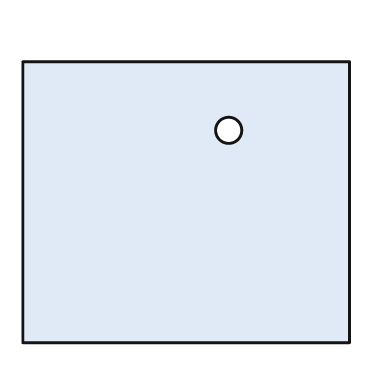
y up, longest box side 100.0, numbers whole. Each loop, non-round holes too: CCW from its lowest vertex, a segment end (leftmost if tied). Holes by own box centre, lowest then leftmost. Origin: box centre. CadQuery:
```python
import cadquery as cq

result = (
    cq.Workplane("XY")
    .moveTo(-50.0, -43.0)
    .lineTo(50.0, -43.0)
    .lineTo(50.0, 43.0)
    .lineTo(-50.0, 43.0)
    .close()
    .moveTo(13.0, 22.0)
    .circle(4.0)
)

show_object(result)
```